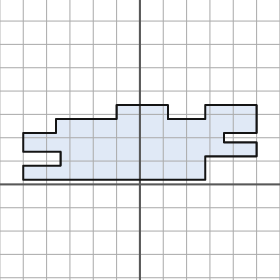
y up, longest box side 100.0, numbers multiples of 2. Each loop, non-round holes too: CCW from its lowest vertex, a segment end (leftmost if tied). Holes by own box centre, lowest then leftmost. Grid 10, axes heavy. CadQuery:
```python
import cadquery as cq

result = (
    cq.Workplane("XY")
    .moveTo(-50.0, 2.0)
    .lineTo(28.0, 2.0)
    .lineTo(28.0, 12.0)
    .lineTo(50.0, 12.0)
    .lineTo(50.0, 18.0)
    .lineTo(36.0, 18.0)
    .lineTo(36.0, 22.0)
    .lineTo(50.0, 22.0)
    .lineTo(50.0, 34.0)
    .lineTo(28.0, 34.0)
    .lineTo(28.0, 28.0)
    .lineTo(12.0, 28.0)
    .lineTo(12.0, 34.0)
    .lineTo(-10.0, 34.0)
    .lineTo(-10.0, 28.0)
    .lineTo(-36.0, 28.0)
    .lineTo(-36.0, 22.0)
    .lineTo(-50.0, 22.0)
    .lineTo(-50.0, 14.0)
    .lineTo(-34.0, 14.0)
    .lineTo(-34.0, 8.0)
    .lineTo(-50.0, 8.0)
    .close()
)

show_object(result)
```